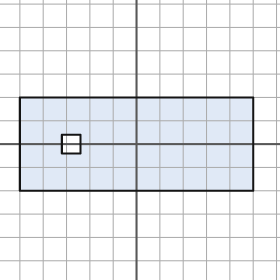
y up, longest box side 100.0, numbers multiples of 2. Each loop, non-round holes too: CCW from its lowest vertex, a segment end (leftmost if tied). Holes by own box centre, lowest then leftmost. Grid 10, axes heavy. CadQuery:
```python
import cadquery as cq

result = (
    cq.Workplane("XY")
    .moveTo(-50.0, -20.0)
    .lineTo(50.0, -20.0)
    .lineTo(50.0, 20.0)
    .lineTo(-50.0, 20.0)
    .close()
    .moveTo(-32.0, -4.0)
    .lineTo(-24.0, -4.0)
    .lineTo(-24.0, 4.0)
    .lineTo(-32.0, 4.0)
    .close()
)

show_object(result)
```